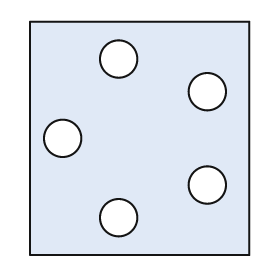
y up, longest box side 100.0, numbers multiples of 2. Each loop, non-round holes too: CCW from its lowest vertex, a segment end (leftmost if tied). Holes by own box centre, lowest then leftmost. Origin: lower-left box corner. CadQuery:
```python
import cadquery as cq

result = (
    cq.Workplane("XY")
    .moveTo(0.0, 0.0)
    .lineTo(94.0, 0.0)
    .lineTo(94.0, 100.0)
    .lineTo(0.0, 100.0)
    .close()
    .moveTo(38.0, 16.0)
    .circle(8.0)
    .moveTo(76.0, 30.0)
    .circle(8.0)
    .moveTo(14.0, 50.0)
    .circle(8.0)
    .moveTo(76.0, 70.0)
    .circle(8.0)
    .moveTo(38.0, 84.0)
    .circle(8.0)
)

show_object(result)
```